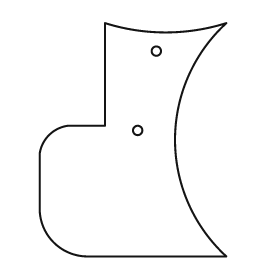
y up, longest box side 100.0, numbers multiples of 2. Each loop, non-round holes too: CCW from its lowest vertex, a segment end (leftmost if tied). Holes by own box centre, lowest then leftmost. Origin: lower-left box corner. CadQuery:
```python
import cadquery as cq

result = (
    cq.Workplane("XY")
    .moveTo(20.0, 0.0)
    .lineTo(80.0, 0.0)
    .threePointArc((58.0, 50.0), (80.0, 100.0))
    .threePointArc((54.0, 96.0), (28.0, 100.0))
    .lineTo(28.0, 56.0)
    .lineTo(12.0, 56.0)
    .threePointArc((4.0, 52.0), (0.0, 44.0))
    .lineTo(0.0, 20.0)
    .threePointArc((6.0, 6.0), (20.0, 0.0))
    .close()
    .moveTo(42.0, 54.0)
    .circle(2.0)
    .moveTo(50.0, 88.0)
    .circle(2.0)
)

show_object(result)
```